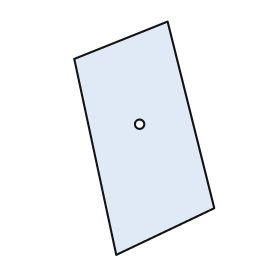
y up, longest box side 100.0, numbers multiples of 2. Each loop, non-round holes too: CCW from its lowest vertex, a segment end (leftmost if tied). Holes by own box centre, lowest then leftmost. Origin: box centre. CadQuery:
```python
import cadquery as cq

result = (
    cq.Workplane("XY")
    .moveTo(-12.0, -50.0)
    .lineTo(30.0, -30.0)
    .lineTo(10.0, 50.0)
    .lineTo(-30.0, 34.0)
    .close()
    .moveTo(-2.0, 6.0)
    .circle(2.0)
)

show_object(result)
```